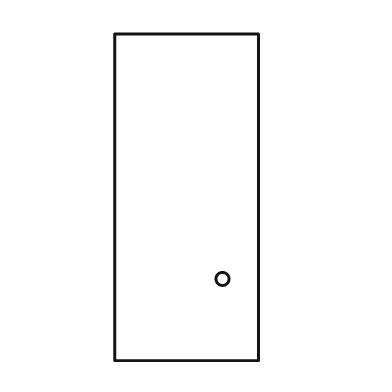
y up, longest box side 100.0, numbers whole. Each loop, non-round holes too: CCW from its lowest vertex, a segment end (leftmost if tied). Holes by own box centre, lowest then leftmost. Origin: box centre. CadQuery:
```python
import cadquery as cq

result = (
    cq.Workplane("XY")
    .moveTo(-22.0, -50.0)
    .lineTo(22.0, -50.0)
    .lineTo(22.0, 50.0)
    .lineTo(-22.0, 50.0)
    .close()
    .moveTo(11.0, -25.0)
    .circle(2.0)
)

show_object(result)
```